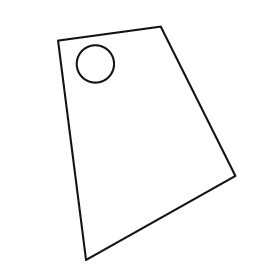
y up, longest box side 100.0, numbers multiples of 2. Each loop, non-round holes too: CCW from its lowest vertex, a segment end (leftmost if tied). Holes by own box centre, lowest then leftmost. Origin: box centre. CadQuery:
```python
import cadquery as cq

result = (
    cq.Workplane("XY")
    .moveTo(-26.0, -50.0)
    .lineTo(38.0, -14.0)
    .lineTo(6.0, 50.0)
    .lineTo(-38.0, 44.0)
    .close()
    .moveTo(-22.0, 34.0)
    .circle(8.0)
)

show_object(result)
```